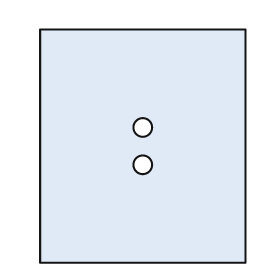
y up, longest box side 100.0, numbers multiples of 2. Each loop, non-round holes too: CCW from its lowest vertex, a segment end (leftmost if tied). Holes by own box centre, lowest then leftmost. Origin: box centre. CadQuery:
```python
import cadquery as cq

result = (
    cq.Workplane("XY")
    .moveTo(-44.0, -50.0)
    .lineTo(44.0, -50.0)
    .lineTo(44.0, 50.0)
    .lineTo(-44.0, 50.0)
    .close()
    .moveTo(0.0, -8.0)
    .circle(4.0)
    .moveTo(0.0, 8.0)
    .circle(4.0)
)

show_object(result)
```